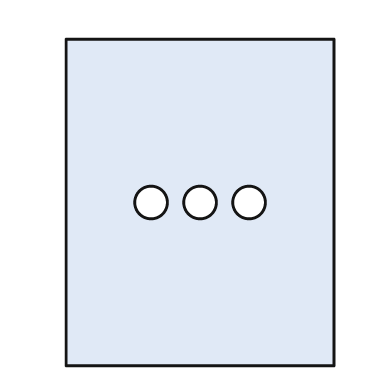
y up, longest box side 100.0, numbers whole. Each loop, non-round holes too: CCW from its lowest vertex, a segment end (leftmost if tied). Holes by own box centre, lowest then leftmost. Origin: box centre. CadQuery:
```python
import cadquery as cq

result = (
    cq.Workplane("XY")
    .moveTo(-41.0, -50.0)
    .lineTo(41.0, -50.0)
    .lineTo(41.0, 50.0)
    .lineTo(-41.0, 50.0)
    .close()
    .moveTo(-15.0, 0.0)
    .circle(5.0)
    .moveTo(0.0, 0.0)
    .circle(5.0)
    .moveTo(15.0, 0.0)
    .circle(5.0)
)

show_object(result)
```